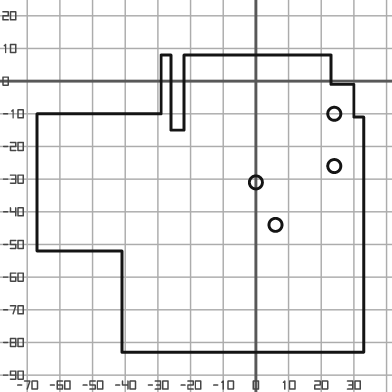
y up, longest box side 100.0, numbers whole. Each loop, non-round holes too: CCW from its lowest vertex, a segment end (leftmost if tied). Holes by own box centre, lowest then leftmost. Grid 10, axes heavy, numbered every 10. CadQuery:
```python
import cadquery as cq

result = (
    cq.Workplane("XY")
    .moveTo(-41.0, -83.0)
    .lineTo(33.0, -83.0)
    .lineTo(33.0, -11.0)
    .lineTo(30.0, -11.0)
    .lineTo(30.0, -1.0)
    .lineTo(23.0, -1.0)
    .lineTo(23.0, 8.0)
    .lineTo(-22.0, 8.0)
    .lineTo(-22.0, -15.0)
    .lineTo(-26.0, -15.0)
    .lineTo(-26.0, 8.0)
    .lineTo(-29.0, 8.0)
    .lineTo(-29.0, -10.0)
    .lineTo(-67.0, -10.0)
    .lineTo(-67.0, -52.0)
    .lineTo(-41.0, -52.0)
    .close()
    .moveTo(6.0, -44.0)
    .circle(2.0)
    .moveTo(0.0, -31.0)
    .circle(2.0)
    .moveTo(24.0, -26.0)
    .circle(2.0)
    .moveTo(24.0, -10.0)
    .circle(2.0)
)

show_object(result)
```